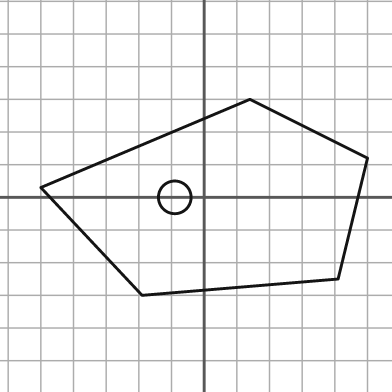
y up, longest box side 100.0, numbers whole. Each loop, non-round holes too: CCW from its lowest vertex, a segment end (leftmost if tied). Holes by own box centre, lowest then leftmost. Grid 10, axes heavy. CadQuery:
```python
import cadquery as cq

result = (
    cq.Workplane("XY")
    .moveTo(-19.0, -30.0)
    .lineTo(41.0, -25.0)
    .lineTo(50.0, 12.0)
    .lineTo(14.0, 30.0)
    .lineTo(-50.0, 3.0)
    .close()
    .moveTo(-9.0, 0.0)
    .circle(5.0)
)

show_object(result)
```